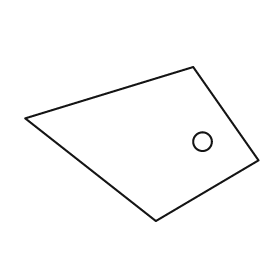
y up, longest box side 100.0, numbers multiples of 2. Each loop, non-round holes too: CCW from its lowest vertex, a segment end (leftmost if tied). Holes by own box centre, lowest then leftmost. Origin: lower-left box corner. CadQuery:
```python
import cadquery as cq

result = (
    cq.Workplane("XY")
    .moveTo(56.0, 0.0)
    .lineTo(100.0, 26.0)
    .lineTo(72.0, 66.0)
    .lineTo(0.0, 44.0)
    .close()
    .moveTo(76.0, 34.0)
    .circle(4.0)
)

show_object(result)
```